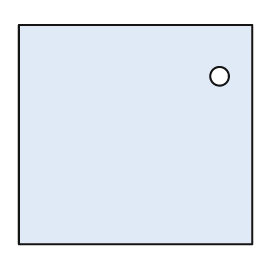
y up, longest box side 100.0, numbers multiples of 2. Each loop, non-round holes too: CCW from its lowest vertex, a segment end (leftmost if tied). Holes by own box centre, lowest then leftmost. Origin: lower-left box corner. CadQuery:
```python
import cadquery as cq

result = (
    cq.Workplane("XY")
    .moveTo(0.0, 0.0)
    .lineTo(100.0, 0.0)
    .lineTo(100.0, 94.0)
    .lineTo(0.0, 94.0)
    .close()
    .moveTo(86.0, 72.0)
    .circle(4.0)
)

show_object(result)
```